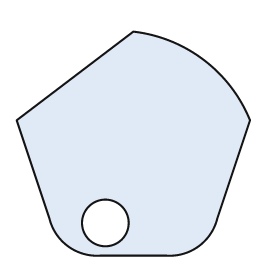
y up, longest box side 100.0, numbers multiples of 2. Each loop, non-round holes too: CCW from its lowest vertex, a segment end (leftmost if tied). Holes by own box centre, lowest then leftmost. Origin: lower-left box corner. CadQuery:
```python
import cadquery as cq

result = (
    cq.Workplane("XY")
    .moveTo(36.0, 0.0)
    .lineTo(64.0, 0.0)
    .threePointArc((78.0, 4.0), (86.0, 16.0))
    .lineTo(100.0, 58.0)
    .threePointArc((80.0, 84.0), (50.0, 96.0))
    .lineTo(0.0, 58.0)
    .lineTo(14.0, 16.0)
    .threePointArc((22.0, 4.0), (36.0, 0.0))
    .close()
    .moveTo(38.0, 14.0)
    .circle(10.0)
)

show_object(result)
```